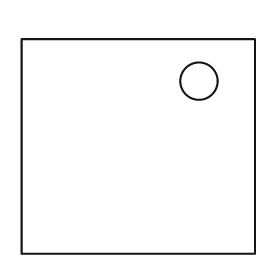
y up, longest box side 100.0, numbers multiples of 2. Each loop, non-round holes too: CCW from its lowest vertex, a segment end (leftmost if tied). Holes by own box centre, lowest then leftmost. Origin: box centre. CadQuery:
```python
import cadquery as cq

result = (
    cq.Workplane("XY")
    .moveTo(-50.0, -46.0)
    .lineTo(50.0, -46.0)
    .lineTo(50.0, 46.0)
    .lineTo(-50.0, 46.0)
    .close()
    .moveTo(26.0, 28.0)
    .circle(8.0)
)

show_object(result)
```